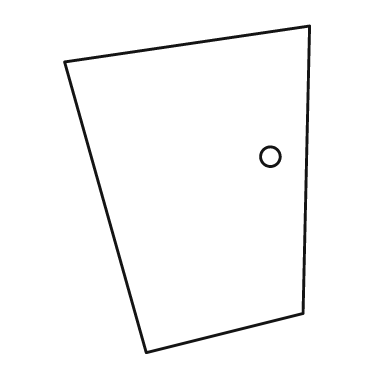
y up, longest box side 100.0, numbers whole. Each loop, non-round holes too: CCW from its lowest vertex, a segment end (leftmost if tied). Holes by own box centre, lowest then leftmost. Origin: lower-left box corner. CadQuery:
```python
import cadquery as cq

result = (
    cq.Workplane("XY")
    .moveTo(25.0, 0.0)
    .lineTo(73.0, 12.0)
    .lineTo(75.0, 100.0)
    .lineTo(0.0, 89.0)
    .close()
    .moveTo(63.0, 60.0)
    .circle(3.0)
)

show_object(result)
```